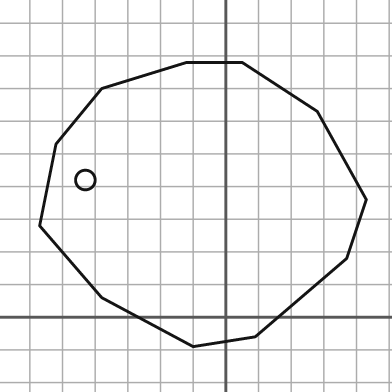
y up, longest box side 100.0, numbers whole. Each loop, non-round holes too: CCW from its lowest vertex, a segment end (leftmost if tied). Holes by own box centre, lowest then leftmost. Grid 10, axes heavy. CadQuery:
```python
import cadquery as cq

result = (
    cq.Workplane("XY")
    .moveTo(-10.0, -9.0)
    .lineTo(9.0, -6.0)
    .lineTo(37.0, 18.0)
    .lineTo(43.0, 36.0)
    .lineTo(28.0, 63.0)
    .lineTo(5.0, 78.0)
    .lineTo(-12.0, 78.0)
    .lineTo(-38.0, 70.0)
    .lineTo(-52.0, 53.0)
    .lineTo(-57.0, 28.0)
    .lineTo(-38.0, 6.0)
    .close()
    .moveTo(-43.0, 42.0)
    .circle(3.0)
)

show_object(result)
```